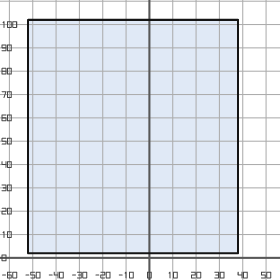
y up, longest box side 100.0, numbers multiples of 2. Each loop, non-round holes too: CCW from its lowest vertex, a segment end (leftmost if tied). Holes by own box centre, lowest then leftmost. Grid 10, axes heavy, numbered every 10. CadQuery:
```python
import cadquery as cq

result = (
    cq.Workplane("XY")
    .moveTo(-52.0, 2.0)
    .lineTo(38.0, 2.0)
    .lineTo(38.0, 102.0)
    .lineTo(-52.0, 102.0)
    .close()
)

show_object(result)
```